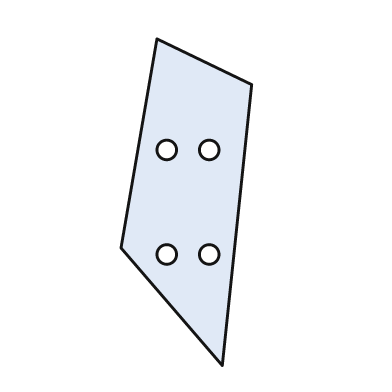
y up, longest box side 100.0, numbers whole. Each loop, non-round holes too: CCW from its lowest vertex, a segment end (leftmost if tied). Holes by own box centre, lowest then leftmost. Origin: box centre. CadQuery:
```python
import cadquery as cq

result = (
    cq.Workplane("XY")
    .moveTo(11.0, -50.0)
    .lineTo(20.0, 36.0)
    .lineTo(-9.0, 50.0)
    .lineTo(-20.0, -14.0)
    .close()
    .moveTo(-6.0, -16.0)
    .circle(3.0)
    .moveTo(7.0, -16.0)
    .circle(3.0)
    .moveTo(-6.0, 16.0)
    .circle(3.0)
    .moveTo(7.0, 16.0)
    .circle(3.0)
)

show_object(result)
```